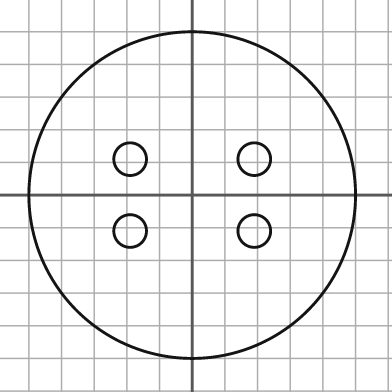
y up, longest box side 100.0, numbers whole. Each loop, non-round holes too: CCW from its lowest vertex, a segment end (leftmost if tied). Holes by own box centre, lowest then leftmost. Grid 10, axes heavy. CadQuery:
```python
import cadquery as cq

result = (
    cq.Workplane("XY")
    .moveTo(0.0, 0.0)
    .circle(50.0)
    .moveTo(-19.0, -11.0)
    .circle(5.0)
    .moveTo(19.0, -11.0)
    .circle(5.0)
    .moveTo(-19.0, 11.0)
    .circle(5.0)
    .moveTo(19.0, 11.0)
    .circle(5.0)
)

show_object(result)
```